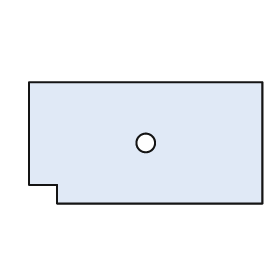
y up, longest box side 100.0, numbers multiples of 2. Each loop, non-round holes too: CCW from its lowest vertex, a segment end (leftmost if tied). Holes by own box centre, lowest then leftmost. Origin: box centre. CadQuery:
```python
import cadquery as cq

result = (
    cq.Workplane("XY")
    .moveTo(-38.0, -26.0)
    .lineTo(50.0, -26.0)
    .lineTo(50.0, 26.0)
    .lineTo(-50.0, 26.0)
    .lineTo(-50.0, -18.0)
    .lineTo(-38.0, -18.0)
    .close()
    .moveTo(0.0, 0.0)
    .circle(4.0)
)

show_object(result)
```